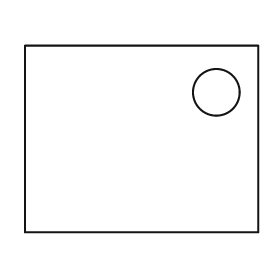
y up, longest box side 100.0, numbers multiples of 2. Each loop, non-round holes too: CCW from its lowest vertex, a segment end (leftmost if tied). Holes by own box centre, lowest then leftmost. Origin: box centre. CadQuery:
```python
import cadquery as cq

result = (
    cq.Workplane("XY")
    .moveTo(-50.0, -40.0)
    .lineTo(50.0, -40.0)
    .lineTo(50.0, 40.0)
    .lineTo(-50.0, 40.0)
    .close()
    .moveTo(32.0, 20.0)
    .circle(10.0)
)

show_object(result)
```